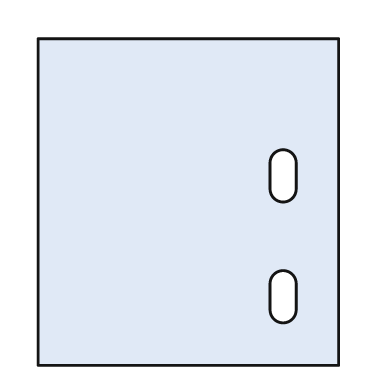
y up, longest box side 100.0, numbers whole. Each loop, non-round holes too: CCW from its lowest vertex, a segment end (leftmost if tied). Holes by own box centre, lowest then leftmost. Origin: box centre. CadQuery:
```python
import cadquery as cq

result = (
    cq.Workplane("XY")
    .moveTo(-46.0, -50.0)
    .lineTo(46.0, -50.0)
    .lineTo(46.0, 50.0)
    .lineTo(-46.0, 50.0)
    .close()
    .moveTo(25.0, -33.0)
    .threePointArc((29.0, -37.0), (33.0, -33.0))
    .lineTo(33.0, -25.0)
    .threePointArc((29.0, -21.0), (25.0, -25.0))
    .close()
    .moveTo(25.0, 4.0)
    .threePointArc((29.0, 0.0), (33.0, 4.0))
    .lineTo(33.0, 12.0)
    .threePointArc((29.0, 16.0), (25.0, 12.0))
    .close()
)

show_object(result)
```